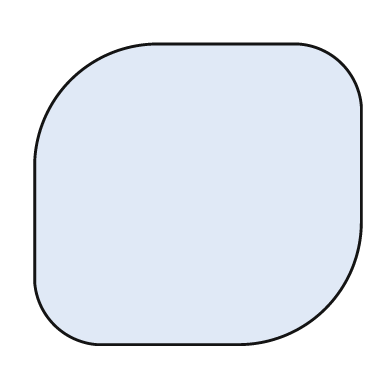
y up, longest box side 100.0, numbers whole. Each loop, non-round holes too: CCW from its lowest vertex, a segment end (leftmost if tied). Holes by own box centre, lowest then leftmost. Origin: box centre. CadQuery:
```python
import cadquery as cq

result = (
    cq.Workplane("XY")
    .moveTo(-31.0, -46.0)
    .lineTo(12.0, -46.0)
    .threePointArc((39.0, -35.0), (50.0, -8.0))
    .lineTo(50.0, 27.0)
    .threePointArc((44.0, 40.0), (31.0, 46.0))
    .lineTo(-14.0, 46.0)
    .threePointArc((-39.0, 35.0), (-50.0, 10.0))
    .lineTo(-50.0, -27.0)
    .threePointArc((-44.0, -40.0), (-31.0, -46.0))
    .close()
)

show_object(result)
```